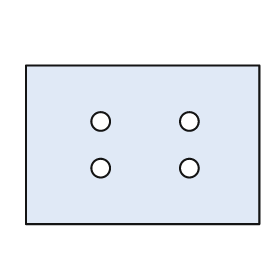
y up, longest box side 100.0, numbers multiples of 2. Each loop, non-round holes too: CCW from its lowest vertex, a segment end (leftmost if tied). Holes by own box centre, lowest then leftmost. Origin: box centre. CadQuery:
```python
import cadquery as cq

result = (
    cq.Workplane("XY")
    .moveTo(-50.0, -34.0)
    .lineTo(50.0, -34.0)
    .lineTo(50.0, 34.0)
    .lineTo(-50.0, 34.0)
    .close()
    .moveTo(-18.0, -10.0)
    .circle(4.0)
    .moveTo(20.0, -10.0)
    .circle(4.0)
    .moveTo(-18.0, 10.0)
    .circle(4.0)
    .moveTo(20.0, 10.0)
    .circle(4.0)
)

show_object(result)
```